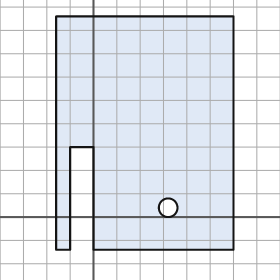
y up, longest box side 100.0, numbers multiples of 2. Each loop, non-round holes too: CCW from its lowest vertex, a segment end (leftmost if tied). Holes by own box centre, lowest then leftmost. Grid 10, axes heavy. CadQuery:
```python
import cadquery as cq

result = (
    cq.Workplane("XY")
    .moveTo(-16.0, -14.0)
    .lineTo(-10.0, -14.0)
    .lineTo(-10.0, 30.0)
    .lineTo(0.0, 30.0)
    .lineTo(0.0, -14.0)
    .lineTo(60.0, -14.0)
    .lineTo(60.0, 86.0)
    .lineTo(-16.0, 86.0)
    .close()
    .moveTo(32.0, 4.0)
    .circle(4.0)
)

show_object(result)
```